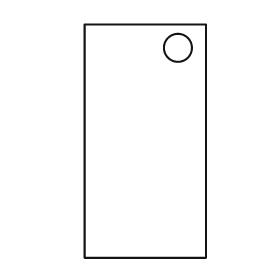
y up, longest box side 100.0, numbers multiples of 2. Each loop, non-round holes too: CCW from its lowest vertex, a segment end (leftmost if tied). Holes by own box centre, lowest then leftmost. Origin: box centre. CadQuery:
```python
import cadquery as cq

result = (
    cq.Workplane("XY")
    .moveTo(-26.0, -50.0)
    .lineTo(26.0, -50.0)
    .lineTo(26.0, 50.0)
    .lineTo(-26.0, 50.0)
    .close()
    .moveTo(14.0, 40.0)
    .circle(6.0)
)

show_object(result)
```